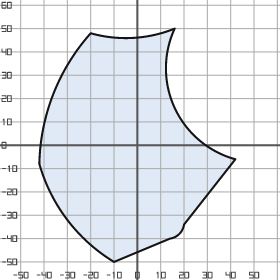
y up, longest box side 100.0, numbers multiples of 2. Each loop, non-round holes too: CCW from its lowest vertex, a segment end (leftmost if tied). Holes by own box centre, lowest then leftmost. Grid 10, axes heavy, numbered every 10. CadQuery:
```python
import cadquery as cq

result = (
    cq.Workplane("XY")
    .moveTo(-10.0, -50.0)
    .lineTo(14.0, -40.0)
    .threePointArc((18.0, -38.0), (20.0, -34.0))
    .lineTo(42.0, -6.0)
    .threePointArc((16.0, 16.0), (16.0, 50.0))
    .threePointArc((-2.0, 46.0), (-20.0, 48.0))
    .threePointArc((-36.0, 22.0), (-42.0, -8.0))
    .threePointArc((-30.0, -32.0), (-10.0, -50.0))
    .close()
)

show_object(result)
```